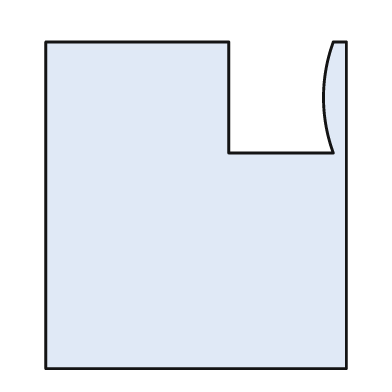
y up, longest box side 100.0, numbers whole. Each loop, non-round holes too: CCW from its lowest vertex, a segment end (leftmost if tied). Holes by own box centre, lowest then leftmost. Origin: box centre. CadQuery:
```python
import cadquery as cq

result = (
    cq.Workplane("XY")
    .moveTo(-46.0, -50.0)
    .lineTo(46.0, -50.0)
    .lineTo(46.0, 50.0)
    .lineTo(42.0, 50.0)
    .threePointArc((39.0, 33.0), (42.0, 16.0))
    .lineTo(10.0, 16.0)
    .lineTo(10.0, 50.0)
    .lineTo(-46.0, 50.0)
    .close()
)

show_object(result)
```